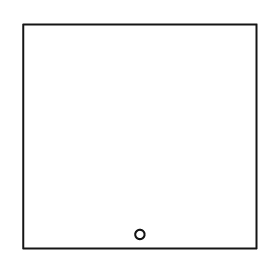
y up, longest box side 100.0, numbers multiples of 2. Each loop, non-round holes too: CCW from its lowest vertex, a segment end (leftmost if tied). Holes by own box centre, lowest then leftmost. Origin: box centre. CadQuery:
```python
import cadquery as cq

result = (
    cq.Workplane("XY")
    .moveTo(-50.0, -48.0)
    .lineTo(50.0, -48.0)
    .lineTo(50.0, 48.0)
    .lineTo(-50.0, 48.0)
    .close()
    .moveTo(0.0, -42.0)
    .circle(2.0)
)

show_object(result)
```